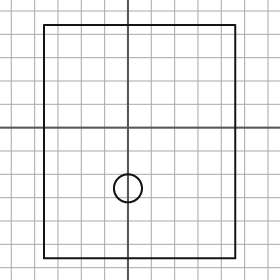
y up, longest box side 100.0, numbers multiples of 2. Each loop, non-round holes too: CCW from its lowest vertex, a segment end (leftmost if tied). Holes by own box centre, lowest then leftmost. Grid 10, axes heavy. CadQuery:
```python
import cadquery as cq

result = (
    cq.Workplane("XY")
    .moveTo(-36.0, -56.0)
    .lineTo(46.0, -56.0)
    .lineTo(46.0, 44.0)
    .lineTo(-36.0, 44.0)
    .close()
    .moveTo(0.0, -26.0)
    .circle(6.0)
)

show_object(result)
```